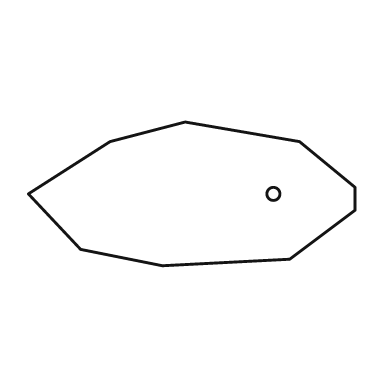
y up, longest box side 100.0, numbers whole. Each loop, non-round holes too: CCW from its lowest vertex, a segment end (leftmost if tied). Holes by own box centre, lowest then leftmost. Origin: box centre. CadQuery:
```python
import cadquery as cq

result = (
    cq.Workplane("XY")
    .moveTo(-9.0, -22.0)
    .lineTo(30.0, -20.0)
    .lineTo(50.0, -5.0)
    .lineTo(50.0, 2.0)
    .lineTo(33.0, 16.0)
    .lineTo(-2.0, 22.0)
    .lineTo(-25.0, 16.0)
    .lineTo(-50.0, 0.0)
    .lineTo(-34.0, -17.0)
    .close()
    .moveTo(25.0, 0.0)
    .circle(2.0)
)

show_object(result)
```